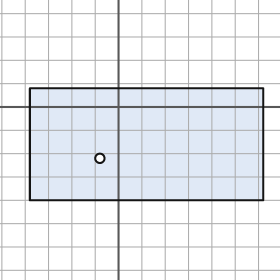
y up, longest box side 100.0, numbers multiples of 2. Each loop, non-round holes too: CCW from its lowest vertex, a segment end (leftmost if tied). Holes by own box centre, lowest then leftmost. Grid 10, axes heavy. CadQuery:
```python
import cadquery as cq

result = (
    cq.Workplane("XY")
    .moveTo(-38.0, -40.0)
    .lineTo(62.0, -40.0)
    .lineTo(62.0, 8.0)
    .lineTo(-38.0, 8.0)
    .close()
    .moveTo(-8.0, -22.0)
    .circle(2.0)
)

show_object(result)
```